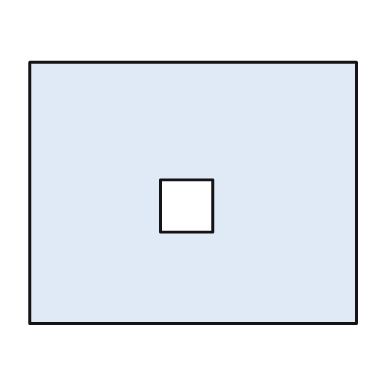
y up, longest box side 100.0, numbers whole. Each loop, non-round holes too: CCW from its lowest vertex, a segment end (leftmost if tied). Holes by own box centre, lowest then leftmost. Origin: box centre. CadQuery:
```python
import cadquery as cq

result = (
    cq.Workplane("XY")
    .moveTo(-50.0, -40.0)
    .lineTo(50.0, -40.0)
    .lineTo(50.0, 40.0)
    .lineTo(-50.0, 40.0)
    .close()
    .moveTo(-10.0, -12.0)
    .lineTo(6.0, -12.0)
    .lineTo(6.0, 4.0)
    .lineTo(-10.0, 4.0)
    .close()
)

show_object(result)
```